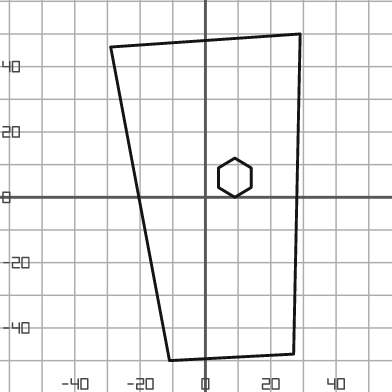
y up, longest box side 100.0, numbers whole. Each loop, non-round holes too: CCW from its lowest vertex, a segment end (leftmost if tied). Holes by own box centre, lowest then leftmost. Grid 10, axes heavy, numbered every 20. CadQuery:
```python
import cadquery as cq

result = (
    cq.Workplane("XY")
    .moveTo(-11.0, -50.0)
    .lineTo(27.0, -48.0)
    .lineTo(29.0, 50.0)
    .lineTo(-29.0, 46.0)
    .close()
    .moveTo(9.0, 0.0)
    .lineTo(14.0, 3.0)
    .lineTo(14.0, 9.0)
    .lineTo(9.0, 12.0)
    .lineTo(4.0, 9.0)
    .lineTo(4.0, 3.0)
    .close()
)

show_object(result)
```